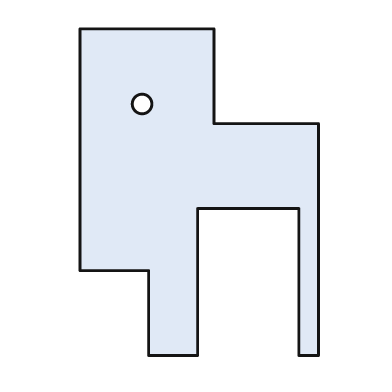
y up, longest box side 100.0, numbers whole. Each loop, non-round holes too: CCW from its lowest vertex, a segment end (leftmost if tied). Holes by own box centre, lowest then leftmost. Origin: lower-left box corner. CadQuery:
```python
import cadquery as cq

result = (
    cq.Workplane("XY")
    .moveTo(21.0, 0.0)
    .lineTo(36.0, 0.0)
    .lineTo(36.0, 45.0)
    .lineTo(67.0, 45.0)
    .lineTo(67.0, 0.0)
    .lineTo(73.0, 0.0)
    .lineTo(73.0, 71.0)
    .lineTo(41.0, 71.0)
    .lineTo(41.0, 100.0)
    .lineTo(0.0, 100.0)
    .lineTo(0.0, 26.0)
    .lineTo(21.0, 26.0)
    .close()
    .moveTo(19.0, 77.0)
    .circle(3.0)
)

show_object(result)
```